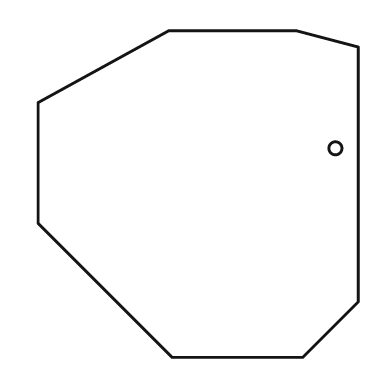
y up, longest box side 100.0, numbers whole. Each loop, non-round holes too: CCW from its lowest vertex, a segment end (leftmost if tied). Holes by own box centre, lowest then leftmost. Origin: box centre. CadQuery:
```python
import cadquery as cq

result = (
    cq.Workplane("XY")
    .moveTo(-8.0, -50.0)
    .lineTo(32.0, -50.0)
    .lineTo(49.0, -33.0)
    .lineTo(49.0, 45.0)
    .lineTo(30.0, 50.0)
    .lineTo(-9.0, 50.0)
    .lineTo(-49.0, 28.0)
    .lineTo(-49.0, -9.0)
    .close()
    .moveTo(42.0, 14.0)
    .circle(2.0)
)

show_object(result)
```